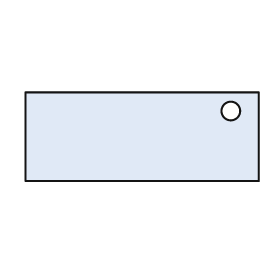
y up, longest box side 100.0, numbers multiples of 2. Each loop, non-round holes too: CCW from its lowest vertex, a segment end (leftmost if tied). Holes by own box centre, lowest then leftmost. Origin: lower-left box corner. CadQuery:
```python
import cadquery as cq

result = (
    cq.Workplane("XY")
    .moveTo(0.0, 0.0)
    .lineTo(100.0, 0.0)
    .lineTo(100.0, 38.0)
    .lineTo(0.0, 38.0)
    .close()
    .moveTo(88.0, 30.0)
    .circle(4.0)
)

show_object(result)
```